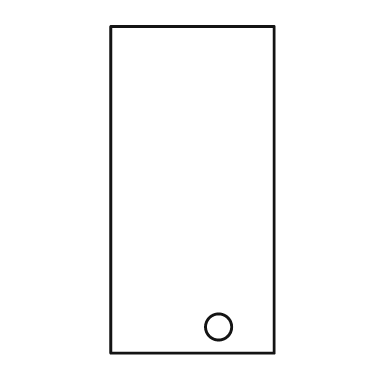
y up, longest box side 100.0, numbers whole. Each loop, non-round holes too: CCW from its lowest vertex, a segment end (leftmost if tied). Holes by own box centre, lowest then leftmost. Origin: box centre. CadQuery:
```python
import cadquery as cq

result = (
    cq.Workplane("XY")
    .moveTo(-25.0, -50.0)
    .lineTo(25.0, -50.0)
    .lineTo(25.0, 50.0)
    .lineTo(-25.0, 50.0)
    .close()
    .moveTo(8.0, -42.0)
    .circle(4.0)
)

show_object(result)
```